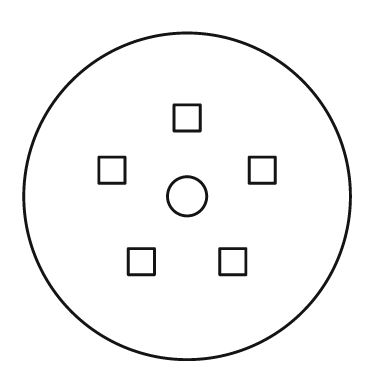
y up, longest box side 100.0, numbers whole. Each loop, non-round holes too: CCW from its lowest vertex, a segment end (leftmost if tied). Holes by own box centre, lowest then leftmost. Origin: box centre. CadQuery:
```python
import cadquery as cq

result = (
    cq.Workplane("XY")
    .moveTo(0.0, 0.0)
    .circle(50.0)
    .moveTo(-18.0, -24.0)
    .lineTo(-10.0, -24.0)
    .lineTo(-10.0, -16.0)
    .lineTo(-18.0, -16.0)
    .close()
    .moveTo(10.0, -24.0)
    .lineTo(18.0, -24.0)
    .lineTo(18.0, -16.0)
    .lineTo(10.0, -16.0)
    .close()
    .moveTo(0.0, 0.0)
    .circle(6.0)
    .moveTo(-27.0, 4.0)
    .lineTo(-19.0, 4.0)
    .lineTo(-19.0, 12.0)
    .lineTo(-27.0, 12.0)
    .close()
    .moveTo(19.0, 4.0)
    .lineTo(27.0, 4.0)
    .lineTo(27.0, 12.0)
    .lineTo(19.0, 12.0)
    .close()
    .moveTo(-4.0, 20.0)
    .lineTo(4.0, 20.0)
    .lineTo(4.0, 28.0)
    .lineTo(-4.0, 28.0)
    .close()
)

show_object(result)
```